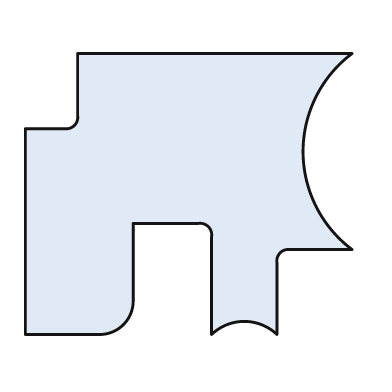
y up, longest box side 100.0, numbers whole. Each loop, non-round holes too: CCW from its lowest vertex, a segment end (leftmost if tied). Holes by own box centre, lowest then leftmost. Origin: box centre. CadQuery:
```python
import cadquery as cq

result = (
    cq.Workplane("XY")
    .moveTo(-50.0, -43.0)
    .lineTo(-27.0, -43.0)
    .threePointArc((-20.0, -40.0), (-17.0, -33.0))
    .lineTo(-17.0, -9.0)
    .lineTo(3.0, -9.0)
    .threePointArc((6.0, -10.0), (7.0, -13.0))
    .lineTo(7.0, -43.0)
    .threePointArc((17.0, -39.0), (27.0, -43.0))
    .lineTo(27.0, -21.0)
    .threePointArc((28.0, -18.0), (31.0, -17.0))
    .lineTo(50.0, -17.0)
    .threePointArc((35.0, 13.0), (50.0, 43.0))
    .lineTo(-34.0, 43.0)
    .lineTo(-34.0, 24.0)
    .threePointArc((-35.0, 21.0), (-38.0, 20.0))
    .lineTo(-50.0, 20.0)
    .close()
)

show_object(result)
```